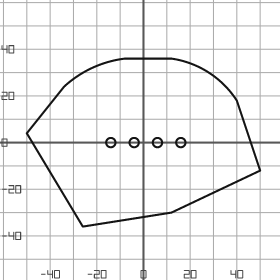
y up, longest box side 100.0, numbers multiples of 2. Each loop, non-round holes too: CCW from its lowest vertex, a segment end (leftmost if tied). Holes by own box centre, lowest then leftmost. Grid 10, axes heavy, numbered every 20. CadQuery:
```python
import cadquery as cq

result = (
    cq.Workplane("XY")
    .moveTo(-26.0, -36.0)
    .lineTo(12.0, -30.0)
    .lineTo(50.0, -12.0)
    .lineTo(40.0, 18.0)
    .threePointArc((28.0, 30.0), (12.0, 36.0))
    .lineTo(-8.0, 36.0)
    .threePointArc((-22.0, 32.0), (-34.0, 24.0))
    .lineTo(-50.0, 4.0)
    .close()
    .moveTo(-14.0, 0.0)
    .circle(2.0)
    .moveTo(-4.0, 0.0)
    .circle(2.0)
    .moveTo(6.0, 0.0)
    .circle(2.0)
    .moveTo(16.0, 0.0)
    .circle(2.0)
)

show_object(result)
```